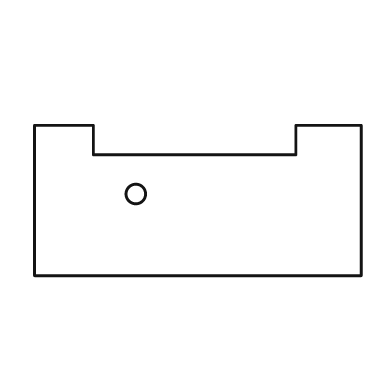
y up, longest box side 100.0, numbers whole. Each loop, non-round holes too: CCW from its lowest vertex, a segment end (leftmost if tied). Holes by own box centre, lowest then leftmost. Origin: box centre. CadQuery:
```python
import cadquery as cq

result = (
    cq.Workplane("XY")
    .moveTo(-50.0, -23.0)
    .lineTo(50.0, -23.0)
    .lineTo(50.0, 23.0)
    .lineTo(30.0, 23.0)
    .lineTo(30.0, 14.0)
    .lineTo(-32.0, 14.0)
    .lineTo(-32.0, 23.0)
    .lineTo(-50.0, 23.0)
    .close()
    .moveTo(-19.0, 2.0)
    .circle(3.0)
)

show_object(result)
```